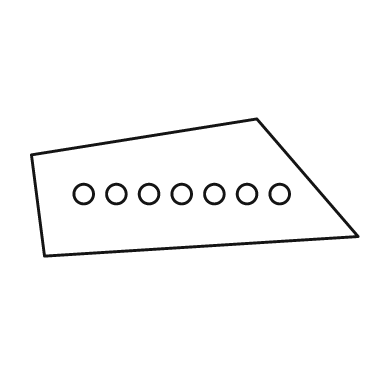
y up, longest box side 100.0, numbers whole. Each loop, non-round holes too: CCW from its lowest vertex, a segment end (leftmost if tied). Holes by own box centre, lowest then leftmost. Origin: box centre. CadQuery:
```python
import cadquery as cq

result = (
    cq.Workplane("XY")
    .moveTo(-46.0, -21.0)
    .lineTo(50.0, -15.0)
    .lineTo(19.0, 21.0)
    .lineTo(-50.0, 10.0)
    .close()
    .moveTo(-34.0, -2.0)
    .circle(3.0)
    .moveTo(-24.0, -2.0)
    .circle(3.0)
    .moveTo(-14.0, -2.0)
    .circle(3.0)
    .moveTo(-4.0, -2.0)
    .circle(3.0)
    .moveTo(6.0, -2.0)
    .circle(3.0)
    .moveTo(16.0, -2.0)
    .circle(3.0)
    .moveTo(26.0, -2.0)
    .circle(3.0)
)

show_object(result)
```